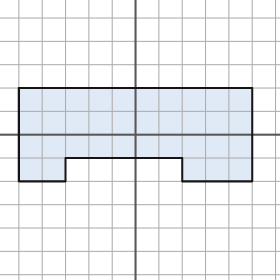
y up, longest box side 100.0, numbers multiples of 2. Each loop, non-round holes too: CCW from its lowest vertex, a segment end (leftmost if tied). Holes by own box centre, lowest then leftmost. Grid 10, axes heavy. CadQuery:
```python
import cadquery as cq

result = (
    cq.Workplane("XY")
    .moveTo(-50.0, -20.0)
    .lineTo(-30.0, -20.0)
    .lineTo(-30.0, -10.0)
    .lineTo(20.0, -10.0)
    .lineTo(20.0, -20.0)
    .lineTo(50.0, -20.0)
    .lineTo(50.0, 20.0)
    .lineTo(-50.0, 20.0)
    .close()
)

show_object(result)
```